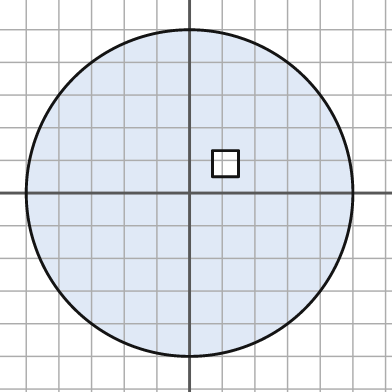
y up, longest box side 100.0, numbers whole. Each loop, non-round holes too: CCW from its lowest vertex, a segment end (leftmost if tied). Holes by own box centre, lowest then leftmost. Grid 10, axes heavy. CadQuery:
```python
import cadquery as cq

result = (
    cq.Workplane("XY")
    .moveTo(0.0, 0.0)
    .circle(50.0)
    .moveTo(7.0, 5.0)
    .lineTo(15.0, 5.0)
    .lineTo(15.0, 13.0)
    .lineTo(7.0, 13.0)
    .close()
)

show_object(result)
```